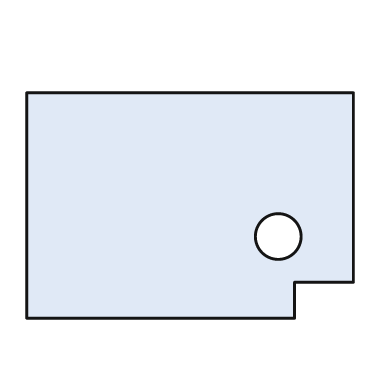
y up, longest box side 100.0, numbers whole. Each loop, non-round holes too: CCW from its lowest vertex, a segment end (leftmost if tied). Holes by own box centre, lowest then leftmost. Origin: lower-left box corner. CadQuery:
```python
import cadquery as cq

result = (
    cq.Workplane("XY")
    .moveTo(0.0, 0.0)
    .lineTo(82.0, 0.0)
    .lineTo(82.0, 11.0)
    .lineTo(100.0, 11.0)
    .lineTo(100.0, 69.0)
    .lineTo(0.0, 69.0)
    .close()
    .moveTo(77.0, 25.0)
    .circle(7.0)
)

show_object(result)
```